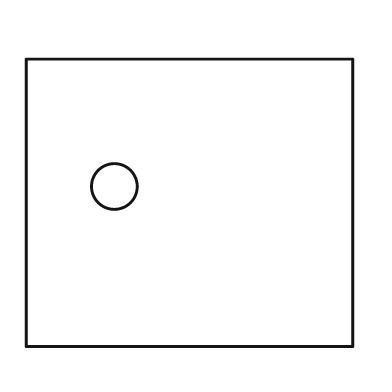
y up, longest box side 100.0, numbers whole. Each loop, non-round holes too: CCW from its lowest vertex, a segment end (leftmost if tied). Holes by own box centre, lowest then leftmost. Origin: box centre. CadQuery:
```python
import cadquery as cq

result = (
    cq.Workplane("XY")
    .moveTo(-50.0, -44.0)
    .lineTo(50.0, -44.0)
    .lineTo(50.0, 44.0)
    .lineTo(-50.0, 44.0)
    .close()
    .moveTo(-23.0, 5.0)
    .circle(7.0)
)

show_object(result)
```